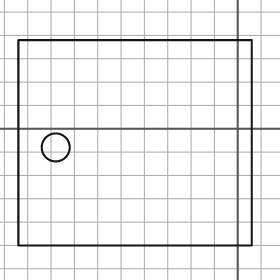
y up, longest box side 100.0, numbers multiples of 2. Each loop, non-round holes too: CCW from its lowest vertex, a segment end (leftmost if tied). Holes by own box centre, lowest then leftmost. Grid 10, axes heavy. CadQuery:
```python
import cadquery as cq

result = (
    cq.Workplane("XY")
    .moveTo(-94.0, -50.0)
    .lineTo(6.0, -50.0)
    .lineTo(6.0, 38.0)
    .lineTo(-94.0, 38.0)
    .close()
    .moveTo(-78.0, -8.0)
    .circle(6.0)
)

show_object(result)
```